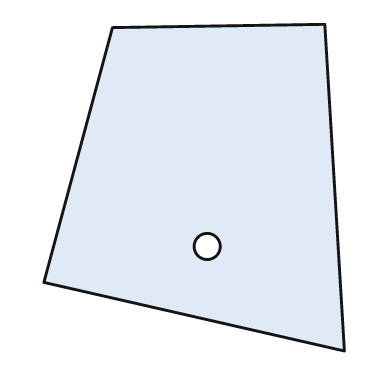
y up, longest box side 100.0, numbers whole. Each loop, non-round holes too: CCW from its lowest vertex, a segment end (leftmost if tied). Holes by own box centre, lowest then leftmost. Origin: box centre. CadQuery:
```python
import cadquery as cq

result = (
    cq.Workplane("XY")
    .moveTo(46.0, -50.0)
    .lineTo(40.0, 50.0)
    .lineTo(-25.0, 49.0)
    .lineTo(-46.0, -29.0)
    .close()
    .moveTo(4.0, -18.0)
    .circle(4.0)
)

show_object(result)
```